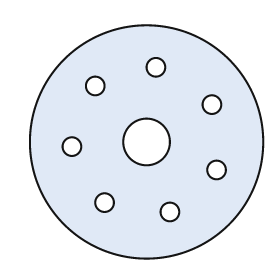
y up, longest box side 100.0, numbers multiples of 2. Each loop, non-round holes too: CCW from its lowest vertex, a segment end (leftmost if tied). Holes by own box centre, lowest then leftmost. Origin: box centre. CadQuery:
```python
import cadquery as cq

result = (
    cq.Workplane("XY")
    .moveTo(0.0, 0.0)
    .circle(50.0)
    .moveTo(10.0, -30.0)
    .circle(4.0)
    .moveTo(-18.0, -26.0)
    .circle(4.0)
    .moveTo(30.0, -12.0)
    .circle(4.0)
    .moveTo(-32.0, -2.0)
    .circle(4.0)
    .moveTo(0.0, 0.0)
    .circle(10.0)
    .moveTo(28.0, 16.0)
    .circle(4.0)
    .moveTo(-22.0, 24.0)
    .circle(4.0)
    .moveTo(4.0, 32.0)
    .circle(4.0)
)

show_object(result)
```